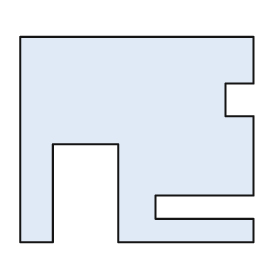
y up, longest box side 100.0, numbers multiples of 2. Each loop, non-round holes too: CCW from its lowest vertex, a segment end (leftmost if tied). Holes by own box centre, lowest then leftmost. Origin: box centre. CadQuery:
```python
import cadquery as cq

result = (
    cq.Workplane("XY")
    .moveTo(-50.0, -44.0)
    .lineTo(-36.0, -44.0)
    .lineTo(-36.0, -2.0)
    .lineTo(-8.0, -2.0)
    .lineTo(-8.0, -44.0)
    .lineTo(50.0, -44.0)
    .lineTo(50.0, -34.0)
    .lineTo(8.0, -34.0)
    .lineTo(8.0, -24.0)
    .lineTo(50.0, -24.0)
    .lineTo(50.0, 10.0)
    .lineTo(38.0, 10.0)
    .lineTo(38.0, 24.0)
    .lineTo(50.0, 24.0)
    .lineTo(50.0, 44.0)
    .lineTo(-50.0, 44.0)
    .close()
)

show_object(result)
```